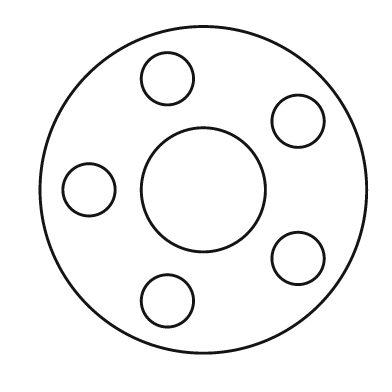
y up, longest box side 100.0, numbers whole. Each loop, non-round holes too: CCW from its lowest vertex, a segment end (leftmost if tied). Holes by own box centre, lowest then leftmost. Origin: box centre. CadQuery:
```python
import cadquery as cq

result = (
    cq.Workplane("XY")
    .moveTo(0.0, 0.0)
    .circle(50.0)
    .moveTo(-11.0, -34.0)
    .circle(8.0)
    .moveTo(29.0, -21.0)
    .circle(8.0)
    .moveTo(-35.0, 0.0)
    .circle(8.0)
    .moveTo(0.0, 0.0)
    .circle(19.0)
    .moveTo(29.0, 21.0)
    .circle(8.0)
    .moveTo(-11.0, 34.0)
    .circle(8.0)
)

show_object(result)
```